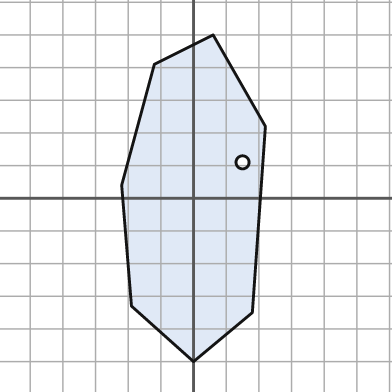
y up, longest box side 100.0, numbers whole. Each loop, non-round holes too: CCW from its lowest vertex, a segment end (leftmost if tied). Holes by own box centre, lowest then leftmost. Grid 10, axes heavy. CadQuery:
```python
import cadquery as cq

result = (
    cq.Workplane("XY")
    .moveTo(0.0, -50.0)
    .lineTo(18.0, -35.0)
    .lineTo(22.0, 22.0)
    .lineTo(6.0, 50.0)
    .lineTo(-12.0, 41.0)
    .lineTo(-22.0, 4.0)
    .lineTo(-19.0, -33.0)
    .close()
    .moveTo(15.0, 11.0)
    .circle(2.0)
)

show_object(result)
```